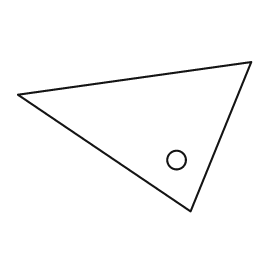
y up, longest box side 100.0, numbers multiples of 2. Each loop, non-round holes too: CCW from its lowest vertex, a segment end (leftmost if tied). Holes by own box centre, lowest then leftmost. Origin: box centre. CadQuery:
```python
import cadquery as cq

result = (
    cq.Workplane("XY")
    .moveTo(24.0, -32.0)
    .lineTo(50.0, 32.0)
    .lineTo(-50.0, 18.0)
    .close()
    .moveTo(18.0, -10.0)
    .circle(4.0)
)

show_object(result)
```